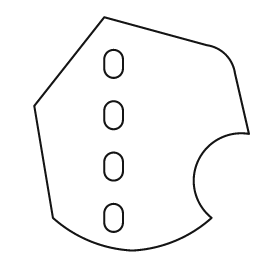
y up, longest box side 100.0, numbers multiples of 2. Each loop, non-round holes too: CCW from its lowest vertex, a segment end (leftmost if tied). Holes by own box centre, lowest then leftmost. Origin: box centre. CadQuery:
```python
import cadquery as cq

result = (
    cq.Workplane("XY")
    .moveTo(-4.0, -50.0)
    .threePointArc((14.0, -46.0), (30.0, -36.0))
    .threePointArc((24.0, -12.0), (46.0, 0.0))
    .lineTo(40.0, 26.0)
    .threePointArc((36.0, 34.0), (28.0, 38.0))
    .lineTo(-16.0, 50.0)
    .lineTo(-46.0, 12.0)
    .lineTo(-38.0, -36.0)
    .threePointArc((-22.0, -46.0), (-4.0, -50.0))
    .close()
    .moveTo(-16.0, -38.0)
    .threePointArc((-12.0, -42.0), (-8.0, -38.0))
    .lineTo(-8.0, -34.0)
    .threePointArc((-12.0, -30.0), (-16.0, -34.0))
    .close()
    .moveTo(-16.0, -16.0)
    .threePointArc((-12.0, -20.0), (-8.0, -16.0))
    .lineTo(-8.0, -12.0)
    .threePointArc((-12.0, -8.0), (-16.0, -12.0))
    .close()
    .moveTo(-16.0, 6.0)
    .threePointArc((-12.0, 2.0), (-8.0, 6.0))
    .lineTo(-8.0, 10.0)
    .threePointArc((-12.0, 14.0), (-16.0, 10.0))
    .close()
    .moveTo(-16.0, 28.0)
    .threePointArc((-12.0, 24.0), (-8.0, 28.0))
    .lineTo(-8.0, 32.0)
    .threePointArc((-12.0, 36.0), (-16.0, 32.0))
    .close()
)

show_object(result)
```